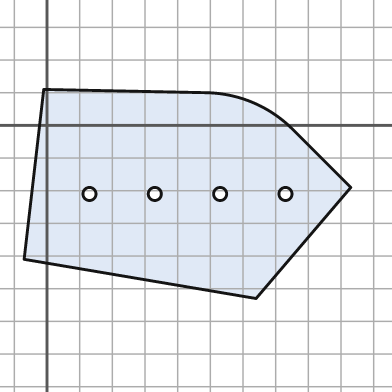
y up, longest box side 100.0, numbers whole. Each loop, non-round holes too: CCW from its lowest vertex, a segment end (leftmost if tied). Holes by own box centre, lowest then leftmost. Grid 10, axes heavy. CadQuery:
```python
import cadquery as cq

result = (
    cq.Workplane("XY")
    .moveTo(64.0, -53.0)
    .lineTo(93.0, -19.0)
    .lineTo(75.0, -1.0)
    .threePointArc((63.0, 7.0), (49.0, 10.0))
    .lineTo(-1.0, 11.0)
    .lineTo(-7.0, -41.0)
    .close()
    .moveTo(13.0, -21.0)
    .circle(2.0)
    .moveTo(33.0, -21.0)
    .circle(2.0)
    .moveTo(53.0, -21.0)
    .circle(2.0)
    .moveTo(73.0, -21.0)
    .circle(2.0)
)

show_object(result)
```